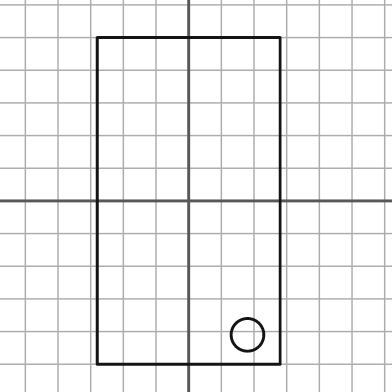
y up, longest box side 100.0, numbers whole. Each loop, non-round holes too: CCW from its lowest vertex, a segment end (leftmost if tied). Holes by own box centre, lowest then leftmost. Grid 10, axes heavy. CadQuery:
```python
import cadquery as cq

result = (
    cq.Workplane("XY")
    .moveTo(-28.0, -50.0)
    .lineTo(28.0, -50.0)
    .lineTo(28.0, 50.0)
    .lineTo(-28.0, 50.0)
    .close()
    .moveTo(18.0, -41.0)
    .circle(5.0)
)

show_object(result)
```